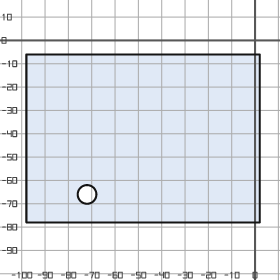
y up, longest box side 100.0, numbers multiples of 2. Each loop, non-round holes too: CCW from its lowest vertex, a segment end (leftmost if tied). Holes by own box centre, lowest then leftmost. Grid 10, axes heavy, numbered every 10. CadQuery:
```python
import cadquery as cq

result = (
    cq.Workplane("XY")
    .moveTo(-98.0, -78.0)
    .lineTo(2.0, -78.0)
    .lineTo(2.0, -6.0)
    .lineTo(-98.0, -6.0)
    .close()
    .moveTo(-72.0, -66.0)
    .circle(4.0)
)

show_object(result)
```